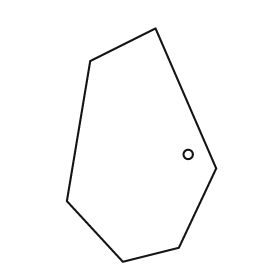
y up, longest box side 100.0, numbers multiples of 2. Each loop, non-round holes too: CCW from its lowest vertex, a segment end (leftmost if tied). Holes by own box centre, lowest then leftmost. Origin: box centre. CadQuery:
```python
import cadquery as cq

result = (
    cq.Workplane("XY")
    .moveTo(-8.0, -50.0)
    .lineTo(16.0, -44.0)
    .lineTo(32.0, -10.0)
    .lineTo(6.0, 50.0)
    .lineTo(-22.0, 36.0)
    .lineTo(-32.0, -24.0)
    .close()
    .moveTo(20.0, -4.0)
    .circle(2.0)
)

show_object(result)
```